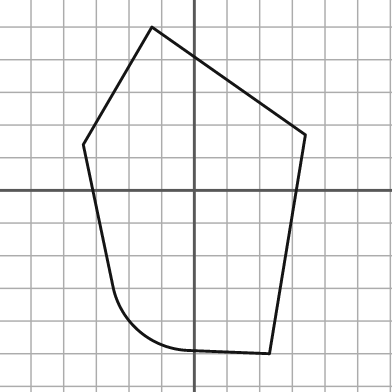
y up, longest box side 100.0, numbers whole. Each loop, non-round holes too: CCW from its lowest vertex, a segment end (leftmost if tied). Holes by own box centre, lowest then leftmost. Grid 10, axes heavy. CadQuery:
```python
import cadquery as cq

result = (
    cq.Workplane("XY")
    .moveTo(23.0, -50.0)
    .lineTo(34.0, 17.0)
    .lineTo(-13.0, 50.0)
    .lineTo(-34.0, 14.0)
    .lineTo(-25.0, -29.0)
    .threePointArc((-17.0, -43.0), (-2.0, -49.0))
    .close()
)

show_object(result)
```